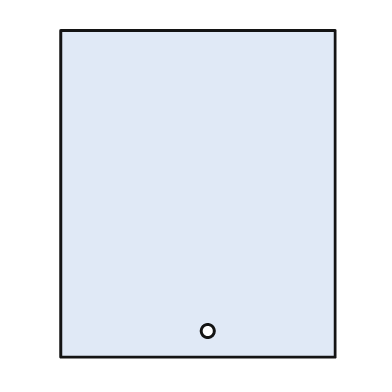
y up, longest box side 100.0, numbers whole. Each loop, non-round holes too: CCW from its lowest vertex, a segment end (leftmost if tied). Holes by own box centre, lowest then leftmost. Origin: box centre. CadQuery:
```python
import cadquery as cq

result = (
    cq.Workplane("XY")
    .moveTo(-42.0, -50.0)
    .lineTo(42.0, -50.0)
    .lineTo(42.0, 50.0)
    .lineTo(-42.0, 50.0)
    .close()
    .moveTo(3.0, -42.0)
    .circle(2.0)
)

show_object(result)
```